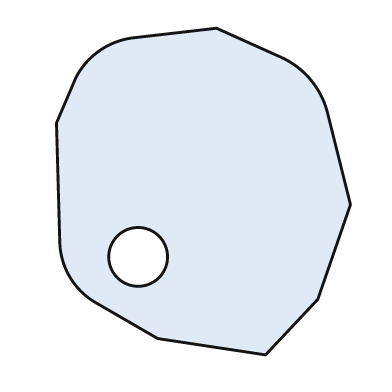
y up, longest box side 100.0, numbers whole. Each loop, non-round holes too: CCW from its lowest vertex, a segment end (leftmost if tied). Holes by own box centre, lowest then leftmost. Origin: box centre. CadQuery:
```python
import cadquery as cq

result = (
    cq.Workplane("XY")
    .moveTo(19.0, -50.0)
    .lineTo(35.0, -33.0)
    .lineTo(45.0, -4.0)
    .lineTo(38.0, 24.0)
    .threePointArc((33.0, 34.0), (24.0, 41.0))
    .lineTo(4.0, 50.0)
    .lineTo(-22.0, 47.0)
    .threePointArc((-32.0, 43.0), (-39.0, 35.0))
    .lineTo(-45.0, 21.0)
    .lineTo(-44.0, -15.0)
    .threePointArc((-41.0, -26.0), (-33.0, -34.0))
    .lineTo(-14.0, -45.0)
    .close()
    .moveTo(-20.0, -20.0)
    .circle(9.0)
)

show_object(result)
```